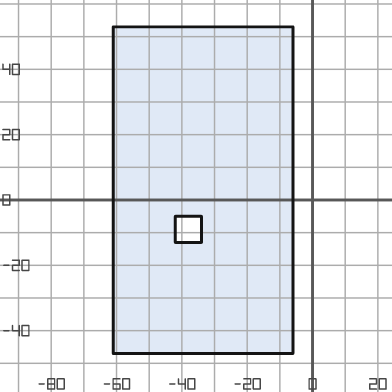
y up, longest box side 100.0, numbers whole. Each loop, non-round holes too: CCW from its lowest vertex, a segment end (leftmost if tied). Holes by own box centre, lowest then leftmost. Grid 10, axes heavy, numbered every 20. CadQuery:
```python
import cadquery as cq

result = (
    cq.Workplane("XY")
    .moveTo(-61.0, -47.0)
    .lineTo(-6.0, -47.0)
    .lineTo(-6.0, 53.0)
    .lineTo(-61.0, 53.0)
    .close()
    .moveTo(-42.0, -13.0)
    .lineTo(-34.0, -13.0)
    .lineTo(-34.0, -5.0)
    .lineTo(-42.0, -5.0)
    .close()
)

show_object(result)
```